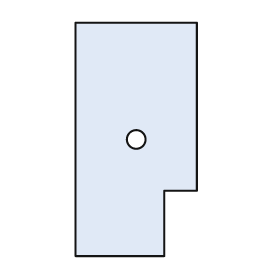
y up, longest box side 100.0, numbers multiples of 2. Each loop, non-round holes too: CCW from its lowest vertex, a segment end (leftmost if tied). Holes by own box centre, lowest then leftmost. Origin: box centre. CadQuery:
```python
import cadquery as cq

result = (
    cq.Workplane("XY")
    .moveTo(-26.0, -50.0)
    .lineTo(12.0, -50.0)
    .lineTo(12.0, -22.0)
    .lineTo(26.0, -22.0)
    .lineTo(26.0, 50.0)
    .lineTo(-26.0, 50.0)
    .close()
    .moveTo(0.0, 0.0)
    .circle(4.0)
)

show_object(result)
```